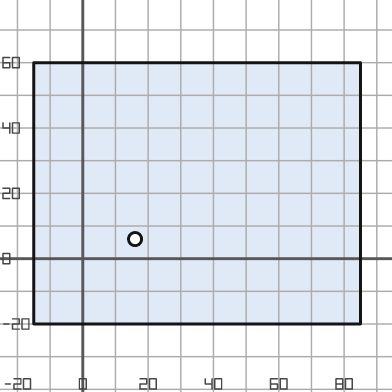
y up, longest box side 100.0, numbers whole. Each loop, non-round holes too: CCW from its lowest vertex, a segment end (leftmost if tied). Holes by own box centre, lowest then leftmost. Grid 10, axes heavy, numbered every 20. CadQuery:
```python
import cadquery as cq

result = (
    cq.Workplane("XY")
    .moveTo(-15.0, -20.0)
    .lineTo(85.0, -20.0)
    .lineTo(85.0, 60.0)
    .lineTo(-15.0, 60.0)
    .close()
    .moveTo(16.0, 6.0)
    .circle(2.0)
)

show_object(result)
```